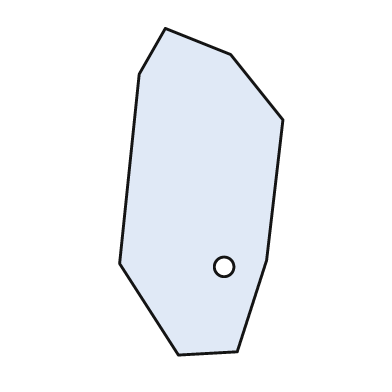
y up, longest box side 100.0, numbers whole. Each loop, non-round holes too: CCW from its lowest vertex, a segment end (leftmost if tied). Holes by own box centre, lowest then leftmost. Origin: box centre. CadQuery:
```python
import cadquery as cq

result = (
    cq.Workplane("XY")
    .moveTo(-7.0, -50.0)
    .lineTo(11.0, -49.0)
    .lineTo(20.0, -21.0)
    .lineTo(25.0, 22.0)
    .lineTo(9.0, 42.0)
    .lineTo(-11.0, 50.0)
    .lineTo(-19.0, 36.0)
    .lineTo(-25.0, -22.0)
    .close()
    .moveTo(7.0, -23.0)
    .circle(3.0)
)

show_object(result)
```